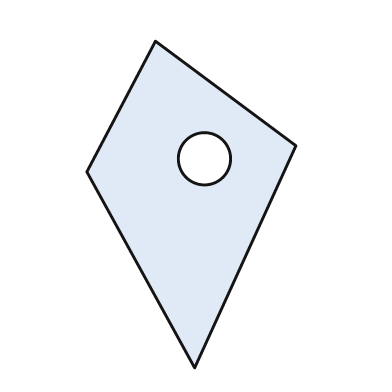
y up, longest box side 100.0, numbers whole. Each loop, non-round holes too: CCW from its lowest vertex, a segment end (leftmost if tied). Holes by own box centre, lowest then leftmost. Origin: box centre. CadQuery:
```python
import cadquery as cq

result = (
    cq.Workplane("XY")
    .moveTo(1.0, -50.0)
    .lineTo(32.0, 18.0)
    .lineTo(-11.0, 50.0)
    .lineTo(-32.0, 10.0)
    .close()
    .moveTo(4.0, 14.0)
    .circle(8.0)
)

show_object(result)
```